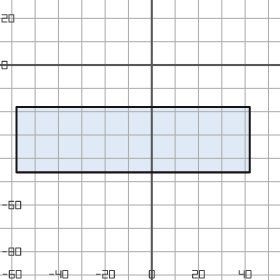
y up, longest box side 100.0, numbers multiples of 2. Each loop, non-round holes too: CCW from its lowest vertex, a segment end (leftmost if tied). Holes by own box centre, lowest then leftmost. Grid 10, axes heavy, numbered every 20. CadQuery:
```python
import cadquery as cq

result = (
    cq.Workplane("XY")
    .moveTo(-58.0, -46.0)
    .lineTo(42.0, -46.0)
    .lineTo(42.0, -18.0)
    .lineTo(-58.0, -18.0)
    .close()
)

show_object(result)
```